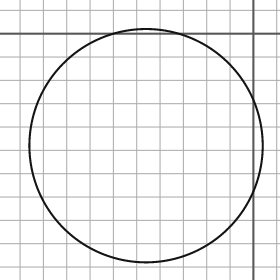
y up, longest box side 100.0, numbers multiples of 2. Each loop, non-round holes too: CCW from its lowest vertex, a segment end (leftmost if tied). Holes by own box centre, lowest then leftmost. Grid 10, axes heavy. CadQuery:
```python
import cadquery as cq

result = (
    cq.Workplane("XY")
    .moveTo(-46.0, -48.0)
    .circle(50.0)
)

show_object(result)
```